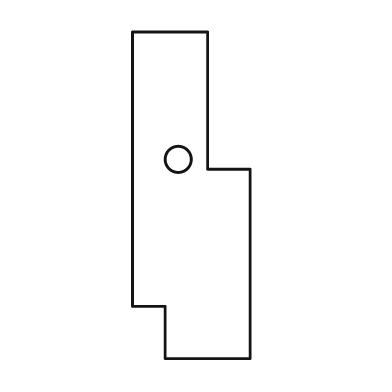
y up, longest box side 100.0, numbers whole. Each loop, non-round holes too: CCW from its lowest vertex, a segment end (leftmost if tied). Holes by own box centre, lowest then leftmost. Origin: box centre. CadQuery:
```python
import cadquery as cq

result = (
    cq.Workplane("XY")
    .moveTo(-8.0, -50.0)
    .lineTo(18.0, -50.0)
    .lineTo(18.0, 8.0)
    .lineTo(5.0, 8.0)
    .lineTo(5.0, 50.0)
    .lineTo(-18.0, 50.0)
    .lineTo(-18.0, -34.0)
    .lineTo(-8.0, -34.0)
    .close()
    .moveTo(-4.0, 11.0)
    .circle(4.0)
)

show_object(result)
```